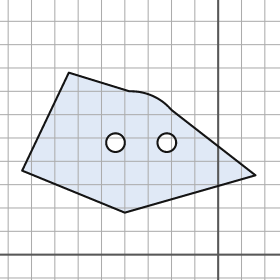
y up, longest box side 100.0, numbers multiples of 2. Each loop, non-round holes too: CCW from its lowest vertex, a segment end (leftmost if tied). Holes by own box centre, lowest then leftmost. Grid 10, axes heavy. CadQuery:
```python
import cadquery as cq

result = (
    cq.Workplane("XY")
    .moveTo(-40.0, 18.0)
    .lineTo(16.0, 34.0)
    .lineTo(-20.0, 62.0)
    .threePointArc((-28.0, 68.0), (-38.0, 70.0))
    .lineTo(-64.0, 78.0)
    .lineTo(-84.0, 36.0)
    .close()
    .moveTo(-44.0, 48.0)
    .circle(4.0)
    .moveTo(-22.0, 48.0)
    .circle(4.0)
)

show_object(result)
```